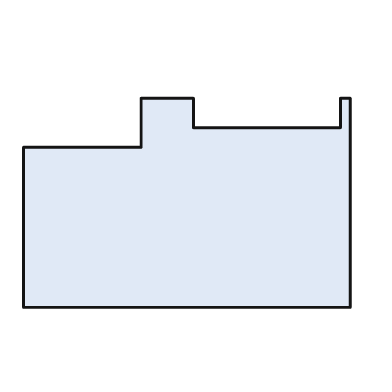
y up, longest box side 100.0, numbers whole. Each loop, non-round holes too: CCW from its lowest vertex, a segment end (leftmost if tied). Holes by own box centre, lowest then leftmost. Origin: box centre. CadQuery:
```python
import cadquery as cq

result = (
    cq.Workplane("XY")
    .moveTo(-50.0, -32.0)
    .lineTo(50.0, -32.0)
    .lineTo(50.0, 32.0)
    .lineTo(47.0, 32.0)
    .lineTo(47.0, 23.0)
    .lineTo(2.0, 23.0)
    .lineTo(2.0, 32.0)
    .lineTo(-14.0, 32.0)
    .lineTo(-14.0, 17.0)
    .lineTo(-50.0, 17.0)
    .close()
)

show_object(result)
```